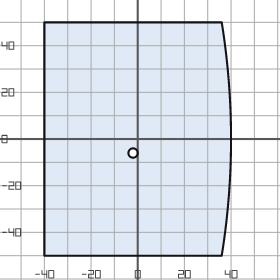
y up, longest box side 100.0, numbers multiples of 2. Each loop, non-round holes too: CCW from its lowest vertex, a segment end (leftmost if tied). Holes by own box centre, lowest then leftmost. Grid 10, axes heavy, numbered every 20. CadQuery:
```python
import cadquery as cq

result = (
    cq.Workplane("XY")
    .moveTo(-40.0, -50.0)
    .lineTo(36.0, -50.0)
    .threePointArc((40.0, 0.0), (36.0, 50.0))
    .lineTo(-40.0, 50.0)
    .close()
    .moveTo(-2.0, -6.0)
    .circle(2.0)
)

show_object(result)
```